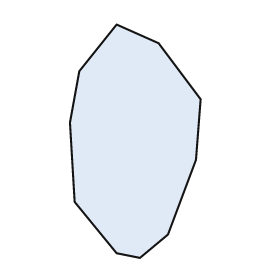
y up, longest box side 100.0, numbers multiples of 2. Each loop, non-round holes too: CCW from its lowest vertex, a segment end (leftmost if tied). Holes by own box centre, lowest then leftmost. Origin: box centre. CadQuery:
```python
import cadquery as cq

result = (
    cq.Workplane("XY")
    .moveTo(2.0, -50.0)
    .lineTo(14.0, -40.0)
    .lineTo(26.0, -8.0)
    .lineTo(28.0, 18.0)
    .lineTo(10.0, 42.0)
    .lineTo(-8.0, 50.0)
    .lineTo(-24.0, 30.0)
    .lineTo(-28.0, 8.0)
    .lineTo(-26.0, -26.0)
    .lineTo(-8.0, -48.0)
    .close()
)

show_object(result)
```